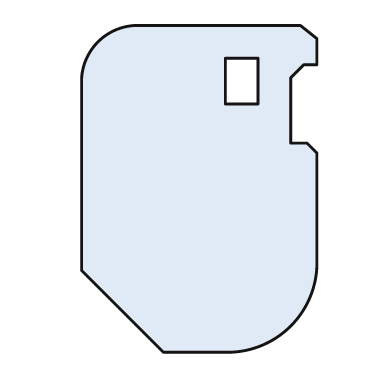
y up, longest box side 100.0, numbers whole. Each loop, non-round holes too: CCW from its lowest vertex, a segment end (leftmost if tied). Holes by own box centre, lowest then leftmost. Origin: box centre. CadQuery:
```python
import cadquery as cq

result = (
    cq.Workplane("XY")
    .moveTo(-11.0, -50.0)
    .lineTo(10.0, -50.0)
    .threePointArc((28.0, -42.0), (36.0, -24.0))
    .lineTo(36.0, 11.0)
    .lineTo(33.0, 14.0)
    .lineTo(28.0, 14.0)
    .lineTo(28.0, 34.0)
    .lineTo(32.0, 38.0)
    .lineTo(36.0, 38.0)
    .lineTo(36.0, 46.0)
    .lineTo(31.0, 50.0)
    .lineTo(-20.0, 50.0)
    .threePointArc((-31.0, 45.0), (-36.0, 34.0))
    .lineTo(-36.0, -25.0)
    .close()
    .moveTo(8.0, 26.0)
    .lineTo(18.0, 26.0)
    .lineTo(18.0, 40.0)
    .lineTo(8.0, 40.0)
    .close()
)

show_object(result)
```